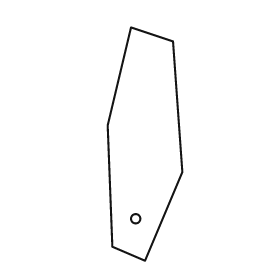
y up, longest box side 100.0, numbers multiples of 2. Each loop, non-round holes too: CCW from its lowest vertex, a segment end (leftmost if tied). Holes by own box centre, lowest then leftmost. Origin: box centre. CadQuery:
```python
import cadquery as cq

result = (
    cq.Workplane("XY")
    .moveTo(0.0, -50.0)
    .lineTo(16.0, -12.0)
    .lineTo(12.0, 44.0)
    .lineTo(-6.0, 50.0)
    .lineTo(-16.0, 8.0)
    .lineTo(-14.0, -44.0)
    .close()
    .moveTo(-4.0, -32.0)
    .circle(2.0)
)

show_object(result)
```